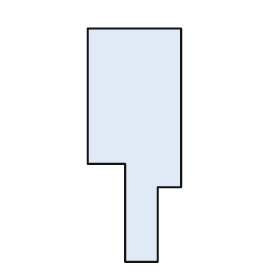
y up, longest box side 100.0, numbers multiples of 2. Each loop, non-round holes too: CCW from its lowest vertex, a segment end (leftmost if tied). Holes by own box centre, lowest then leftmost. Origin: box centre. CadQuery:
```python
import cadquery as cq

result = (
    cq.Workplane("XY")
    .moveTo(-4.0, -50.0)
    .lineTo(10.0, -50.0)
    .lineTo(10.0, -18.0)
    .lineTo(20.0, -18.0)
    .lineTo(20.0, 50.0)
    .lineTo(-20.0, 50.0)
    .lineTo(-20.0, -8.0)
    .lineTo(-4.0, -8.0)
    .close()
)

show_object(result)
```